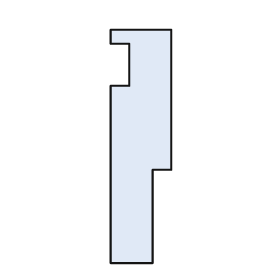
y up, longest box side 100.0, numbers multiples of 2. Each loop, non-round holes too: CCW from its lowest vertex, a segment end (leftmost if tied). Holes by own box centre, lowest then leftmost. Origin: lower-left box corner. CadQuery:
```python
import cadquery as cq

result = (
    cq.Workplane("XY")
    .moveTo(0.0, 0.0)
    .lineTo(18.0, 0.0)
    .lineTo(18.0, 40.0)
    .lineTo(26.0, 40.0)
    .lineTo(26.0, 100.0)
    .lineTo(0.0, 100.0)
    .lineTo(0.0, 94.0)
    .lineTo(8.0, 94.0)
    .lineTo(8.0, 76.0)
    .lineTo(0.0, 76.0)
    .close()
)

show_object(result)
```